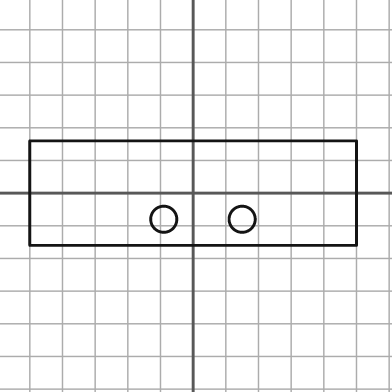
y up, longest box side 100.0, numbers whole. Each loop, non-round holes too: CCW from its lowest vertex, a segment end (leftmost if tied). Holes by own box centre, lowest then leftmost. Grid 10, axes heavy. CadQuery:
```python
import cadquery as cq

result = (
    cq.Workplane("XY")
    .moveTo(-50.0, -16.0)
    .lineTo(50.0, -16.0)
    .lineTo(50.0, 16.0)
    .lineTo(-50.0, 16.0)
    .close()
    .moveTo(-9.0, -8.0)
    .circle(4.0)
    .moveTo(15.0, -8.0)
    .circle(4.0)
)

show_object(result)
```